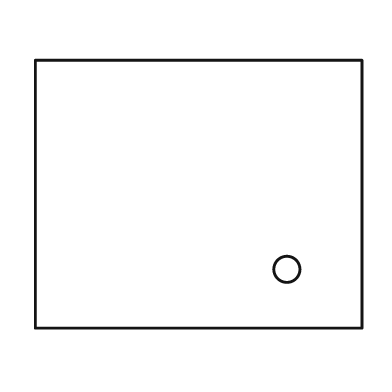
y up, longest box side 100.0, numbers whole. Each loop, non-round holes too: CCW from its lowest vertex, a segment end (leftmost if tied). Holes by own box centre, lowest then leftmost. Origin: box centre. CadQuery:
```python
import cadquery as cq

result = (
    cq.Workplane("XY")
    .moveTo(-50.0, -41.0)
    .lineTo(50.0, -41.0)
    .lineTo(50.0, 41.0)
    .lineTo(-50.0, 41.0)
    .close()
    .moveTo(27.0, -23.0)
    .circle(4.0)
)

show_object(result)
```